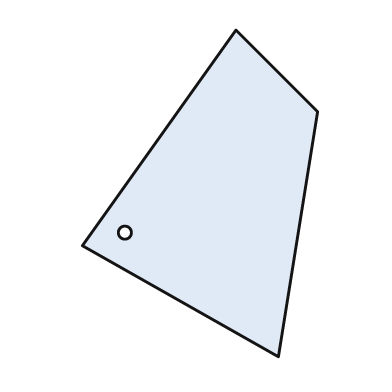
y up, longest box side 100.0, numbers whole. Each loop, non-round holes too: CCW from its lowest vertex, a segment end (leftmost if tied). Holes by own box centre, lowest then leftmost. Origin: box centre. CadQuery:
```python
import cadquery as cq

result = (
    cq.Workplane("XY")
    .moveTo(24.0, -50.0)
    .lineTo(36.0, 25.0)
    .lineTo(11.0, 50.0)
    .lineTo(-36.0, -16.0)
    .close()
    .moveTo(-23.0, -12.0)
    .circle(2.0)
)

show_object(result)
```